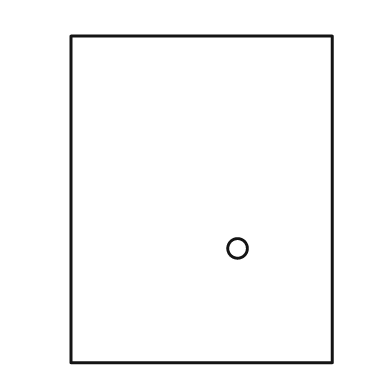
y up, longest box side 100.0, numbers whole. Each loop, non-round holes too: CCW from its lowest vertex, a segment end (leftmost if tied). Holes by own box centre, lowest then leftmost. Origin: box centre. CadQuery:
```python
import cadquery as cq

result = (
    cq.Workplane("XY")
    .moveTo(-40.0, -50.0)
    .lineTo(40.0, -50.0)
    .lineTo(40.0, 50.0)
    .lineTo(-40.0, 50.0)
    .close()
    .moveTo(11.0, -15.0)
    .circle(3.0)
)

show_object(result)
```